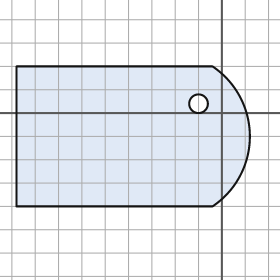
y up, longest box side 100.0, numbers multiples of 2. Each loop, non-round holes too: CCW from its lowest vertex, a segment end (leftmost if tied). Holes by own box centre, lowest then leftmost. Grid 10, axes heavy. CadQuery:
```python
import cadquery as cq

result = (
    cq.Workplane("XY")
    .moveTo(-88.0, -40.0)
    .lineTo(-4.0, -40.0)
    .threePointArc((12.0, -10.0), (-4.0, 20.0))
    .lineTo(-88.0, 20.0)
    .close()
    .moveTo(-10.0, 4.0)
    .circle(4.0)
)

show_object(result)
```